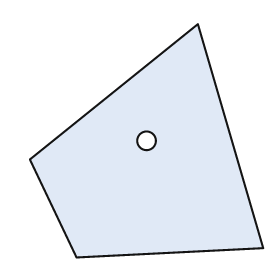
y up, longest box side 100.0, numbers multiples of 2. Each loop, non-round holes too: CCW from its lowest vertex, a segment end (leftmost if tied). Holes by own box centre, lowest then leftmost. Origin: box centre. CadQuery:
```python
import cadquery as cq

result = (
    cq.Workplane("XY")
    .moveTo(-30.0, -50.0)
    .lineTo(50.0, -46.0)
    .lineTo(22.0, 50.0)
    .lineTo(-50.0, -8.0)
    .close()
    .moveTo(0.0, 0.0)
    .circle(4.0)
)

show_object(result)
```